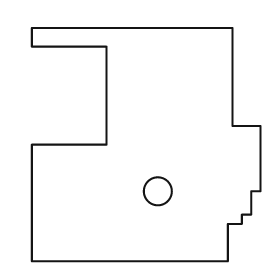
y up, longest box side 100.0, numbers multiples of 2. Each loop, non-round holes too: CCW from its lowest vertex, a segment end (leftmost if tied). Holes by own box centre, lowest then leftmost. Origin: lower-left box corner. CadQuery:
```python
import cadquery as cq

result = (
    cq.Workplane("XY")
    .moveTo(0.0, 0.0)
    .lineTo(84.0, 0.0)
    .lineTo(84.0, 16.0)
    .lineTo(90.0, 16.0)
    .lineTo(90.0, 20.0)
    .lineTo(94.0, 20.0)
    .lineTo(94.0, 30.0)
    .lineTo(98.0, 30.0)
    .lineTo(98.0, 58.0)
    .lineTo(86.0, 58.0)
    .lineTo(86.0, 100.0)
    .lineTo(0.0, 100.0)
    .lineTo(0.0, 92.0)
    .lineTo(32.0, 92.0)
    .lineTo(32.0, 50.0)
    .lineTo(0.0, 50.0)
    .close()
    .moveTo(54.0, 30.0)
    .circle(6.0)
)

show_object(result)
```